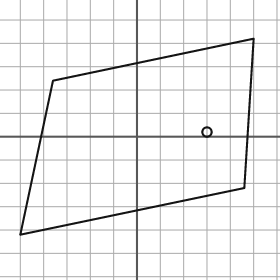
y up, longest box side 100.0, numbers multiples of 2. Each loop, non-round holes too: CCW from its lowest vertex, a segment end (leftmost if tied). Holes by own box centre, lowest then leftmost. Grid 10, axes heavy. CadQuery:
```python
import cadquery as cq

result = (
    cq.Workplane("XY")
    .moveTo(-50.0, -42.0)
    .lineTo(46.0, -22.0)
    .lineTo(50.0, 42.0)
    .lineTo(-36.0, 24.0)
    .close()
    .moveTo(30.0, 2.0)
    .circle(2.0)
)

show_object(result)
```